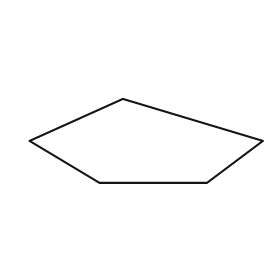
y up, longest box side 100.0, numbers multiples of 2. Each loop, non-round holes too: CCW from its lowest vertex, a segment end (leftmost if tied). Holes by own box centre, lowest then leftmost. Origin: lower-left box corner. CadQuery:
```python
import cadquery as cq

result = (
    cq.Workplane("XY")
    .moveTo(30.0, 0.0)
    .lineTo(76.0, 0.0)
    .lineTo(100.0, 18.0)
    .lineTo(40.0, 36.0)
    .lineTo(0.0, 18.0)
    .close()
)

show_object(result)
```